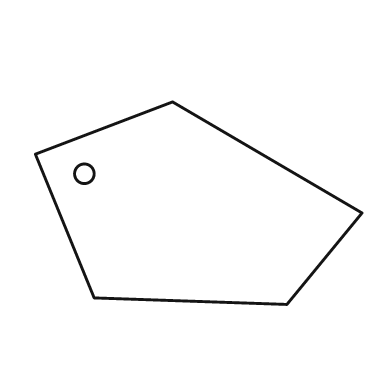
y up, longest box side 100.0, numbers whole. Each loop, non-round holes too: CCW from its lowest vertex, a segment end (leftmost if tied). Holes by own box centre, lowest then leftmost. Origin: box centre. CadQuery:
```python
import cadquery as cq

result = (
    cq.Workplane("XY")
    .moveTo(27.0, -31.0)
    .lineTo(50.0, -3.0)
    .lineTo(-8.0, 31.0)
    .lineTo(-50.0, 15.0)
    .lineTo(-32.0, -29.0)
    .close()
    .moveTo(-35.0, 9.0)
    .circle(3.0)
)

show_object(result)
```